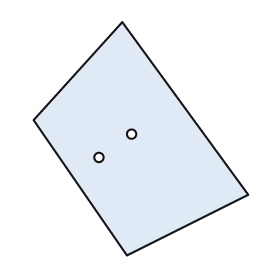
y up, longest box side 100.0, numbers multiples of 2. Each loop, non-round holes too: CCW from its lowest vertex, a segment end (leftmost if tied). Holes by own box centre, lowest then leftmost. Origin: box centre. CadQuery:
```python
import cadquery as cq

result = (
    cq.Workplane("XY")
    .moveTo(-6.0, -50.0)
    .lineTo(46.0, -24.0)
    .lineTo(-8.0, 50.0)
    .lineTo(-46.0, 8.0)
    .close()
    .moveTo(-18.0, -8.0)
    .circle(2.0)
    .moveTo(-4.0, 2.0)
    .circle(2.0)
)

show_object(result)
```